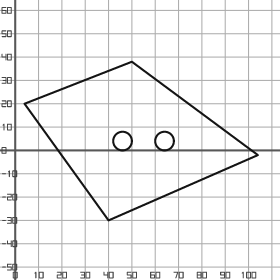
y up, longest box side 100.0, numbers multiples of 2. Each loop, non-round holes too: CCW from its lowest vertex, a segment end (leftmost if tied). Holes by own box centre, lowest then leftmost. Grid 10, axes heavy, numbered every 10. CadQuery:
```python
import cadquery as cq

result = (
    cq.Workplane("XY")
    .moveTo(40.0, -30.0)
    .lineTo(104.0, -2.0)
    .lineTo(50.0, 38.0)
    .lineTo(4.0, 20.0)
    .close()
    .moveTo(46.0, 4.0)
    .circle(4.0)
    .moveTo(64.0, 4.0)
    .circle(4.0)
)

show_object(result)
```